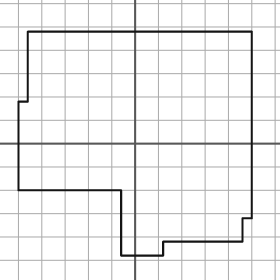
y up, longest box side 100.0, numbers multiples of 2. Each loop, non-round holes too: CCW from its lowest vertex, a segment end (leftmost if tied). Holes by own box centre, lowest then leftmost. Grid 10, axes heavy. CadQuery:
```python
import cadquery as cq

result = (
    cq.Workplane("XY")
    .moveTo(-6.0, -48.0)
    .lineTo(12.0, -48.0)
    .lineTo(12.0, -42.0)
    .lineTo(46.0, -42.0)
    .lineTo(46.0, -32.0)
    .lineTo(50.0, -32.0)
    .lineTo(50.0, 48.0)
    .lineTo(-46.0, 48.0)
    .lineTo(-46.0, 18.0)
    .lineTo(-50.0, 18.0)
    .lineTo(-50.0, -20.0)
    .lineTo(-6.0, -20.0)
    .close()
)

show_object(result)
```